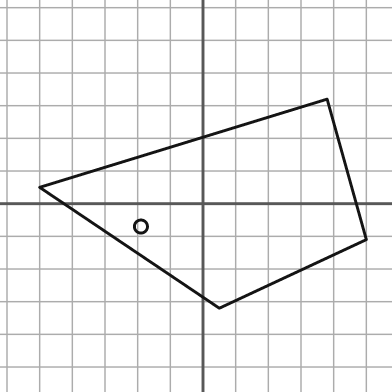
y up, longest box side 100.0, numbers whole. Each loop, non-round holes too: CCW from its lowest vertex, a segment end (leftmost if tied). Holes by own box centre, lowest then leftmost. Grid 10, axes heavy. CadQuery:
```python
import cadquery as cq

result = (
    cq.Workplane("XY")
    .moveTo(5.0, -32.0)
    .lineTo(50.0, -11.0)
    .lineTo(38.0, 32.0)
    .lineTo(-50.0, 5.0)
    .close()
    .moveTo(-19.0, -7.0)
    .circle(2.0)
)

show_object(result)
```